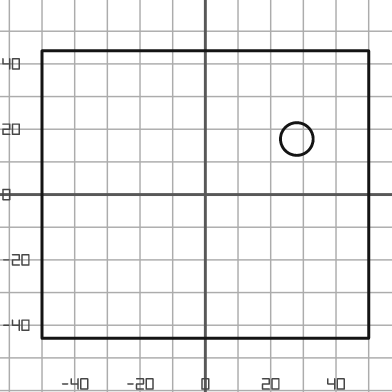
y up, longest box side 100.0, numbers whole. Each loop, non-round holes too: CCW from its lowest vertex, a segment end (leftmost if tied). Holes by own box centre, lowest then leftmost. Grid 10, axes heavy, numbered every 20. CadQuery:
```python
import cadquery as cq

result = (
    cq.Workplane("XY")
    .moveTo(-50.0, -44.0)
    .lineTo(50.0, -44.0)
    .lineTo(50.0, 44.0)
    .lineTo(-50.0, 44.0)
    .close()
    .moveTo(28.0, 17.0)
    .circle(5.0)
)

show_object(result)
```